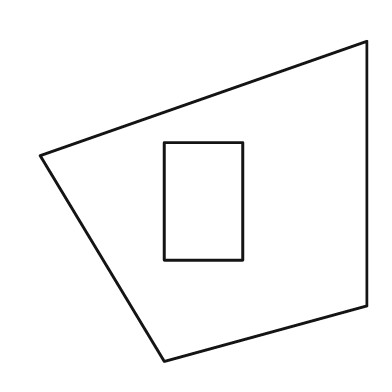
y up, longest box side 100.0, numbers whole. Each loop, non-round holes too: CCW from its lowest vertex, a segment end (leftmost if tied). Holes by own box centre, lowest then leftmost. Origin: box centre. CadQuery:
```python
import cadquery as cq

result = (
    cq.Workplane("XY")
    .moveTo(-12.0, -49.0)
    .lineTo(50.0, -32.0)
    .lineTo(50.0, 49.0)
    .lineTo(-50.0, 14.0)
    .close()
    .moveTo(-12.0, -18.0)
    .lineTo(12.0, -18.0)
    .lineTo(12.0, 18.0)
    .lineTo(-12.0, 18.0)
    .close()
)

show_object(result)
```